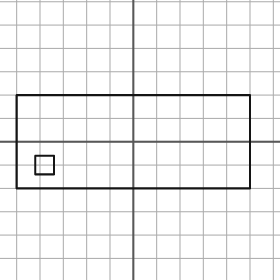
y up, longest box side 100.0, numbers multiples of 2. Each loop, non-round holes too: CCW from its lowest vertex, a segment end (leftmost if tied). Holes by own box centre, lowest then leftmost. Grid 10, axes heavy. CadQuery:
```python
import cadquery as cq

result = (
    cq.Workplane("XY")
    .moveTo(-50.0, -20.0)
    .lineTo(50.0, -20.0)
    .lineTo(50.0, 20.0)
    .lineTo(-50.0, 20.0)
    .close()
    .moveTo(-42.0, -14.0)
    .lineTo(-34.0, -14.0)
    .lineTo(-34.0, -6.0)
    .lineTo(-42.0, -6.0)
    .close()
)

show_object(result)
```